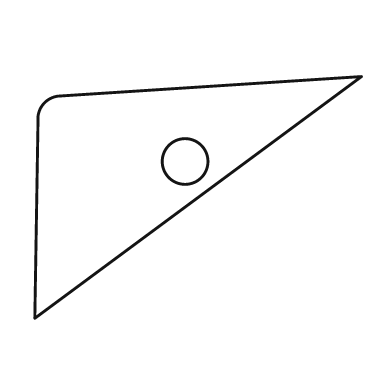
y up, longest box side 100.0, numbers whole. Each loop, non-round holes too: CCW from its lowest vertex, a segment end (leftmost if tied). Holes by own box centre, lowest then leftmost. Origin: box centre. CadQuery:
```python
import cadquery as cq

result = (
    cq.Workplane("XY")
    .moveTo(-50.0, -37.0)
    .lineTo(50.0, 37.0)
    .lineTo(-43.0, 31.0)
    .threePointArc((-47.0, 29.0), (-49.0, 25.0))
    .close()
    .moveTo(-4.0, 11.0)
    .circle(7.0)
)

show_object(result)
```